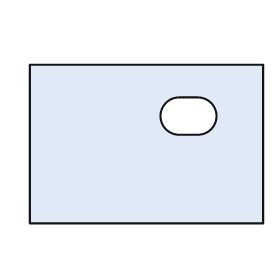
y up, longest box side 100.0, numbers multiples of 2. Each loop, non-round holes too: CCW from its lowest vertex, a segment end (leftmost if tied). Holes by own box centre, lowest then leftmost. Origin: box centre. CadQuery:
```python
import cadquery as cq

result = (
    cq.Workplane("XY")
    .moveTo(-50.0, -34.0)
    .lineTo(50.0, -34.0)
    .lineTo(50.0, 34.0)
    .lineTo(-50.0, 34.0)
    .close()
    .moveTo(14.0, 4.0)
    .lineTo(22.0, 4.0)
    .threePointArc((30.0, 12.0), (22.0, 20.0))
    .lineTo(14.0, 20.0)
    .threePointArc((6.0, 12.0), (14.0, 4.0))
    .close()
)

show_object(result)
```